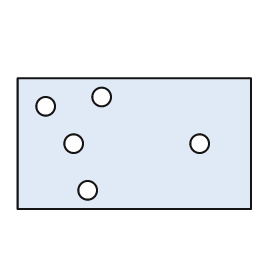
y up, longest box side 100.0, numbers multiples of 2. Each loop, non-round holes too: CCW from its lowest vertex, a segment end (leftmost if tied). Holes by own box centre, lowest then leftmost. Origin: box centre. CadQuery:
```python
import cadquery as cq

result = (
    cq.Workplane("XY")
    .moveTo(-50.0, -28.0)
    .lineTo(50.0, -28.0)
    .lineTo(50.0, 28.0)
    .lineTo(-50.0, 28.0)
    .close()
    .moveTo(-20.0, -20.0)
    .circle(4.0)
    .moveTo(-26.0, 0.0)
    .circle(4.0)
    .moveTo(28.0, 0.0)
    .circle(4.0)
    .moveTo(-38.0, 16.0)
    .circle(4.0)
    .moveTo(-14.0, 20.0)
    .circle(4.0)
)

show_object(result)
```